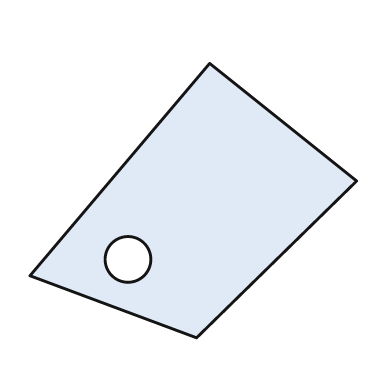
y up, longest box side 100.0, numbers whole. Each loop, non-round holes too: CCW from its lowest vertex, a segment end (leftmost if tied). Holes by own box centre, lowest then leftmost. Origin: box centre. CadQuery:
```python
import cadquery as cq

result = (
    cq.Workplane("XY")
    .moveTo(1.0, -42.0)
    .lineTo(50.0, 6.0)
    .lineTo(5.0, 42.0)
    .lineTo(-50.0, -23.0)
    .close()
    .moveTo(-20.0, -18.0)
    .circle(7.0)
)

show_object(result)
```